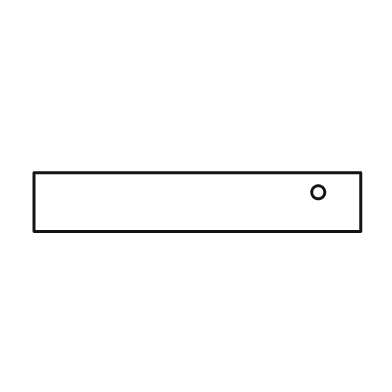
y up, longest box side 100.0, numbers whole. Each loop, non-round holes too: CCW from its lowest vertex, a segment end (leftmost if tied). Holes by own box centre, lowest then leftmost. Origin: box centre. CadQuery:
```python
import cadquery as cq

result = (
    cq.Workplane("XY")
    .moveTo(-50.0, -9.0)
    .lineTo(50.0, -9.0)
    .lineTo(50.0, 9.0)
    .lineTo(-50.0, 9.0)
    .close()
    .moveTo(37.0, 3.0)
    .circle(2.0)
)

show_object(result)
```